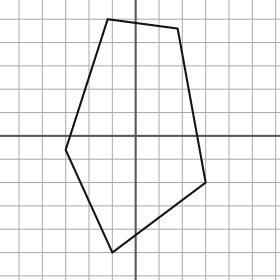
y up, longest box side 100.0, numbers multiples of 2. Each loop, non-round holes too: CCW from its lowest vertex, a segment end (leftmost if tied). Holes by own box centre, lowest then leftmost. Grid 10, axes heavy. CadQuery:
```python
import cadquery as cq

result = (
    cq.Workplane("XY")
    .moveTo(-10.0, -50.0)
    .lineTo(30.0, -20.0)
    .lineTo(18.0, 46.0)
    .lineTo(-12.0, 50.0)
    .lineTo(-30.0, -6.0)
    .close()
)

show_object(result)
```